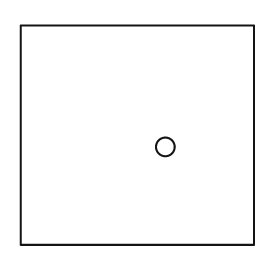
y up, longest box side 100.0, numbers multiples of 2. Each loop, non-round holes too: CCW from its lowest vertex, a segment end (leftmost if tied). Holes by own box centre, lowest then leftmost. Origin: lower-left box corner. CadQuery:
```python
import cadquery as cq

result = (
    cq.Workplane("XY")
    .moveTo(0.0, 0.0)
    .lineTo(100.0, 0.0)
    .lineTo(100.0, 94.0)
    .lineTo(0.0, 94.0)
    .close()
    .moveTo(62.0, 42.0)
    .circle(4.0)
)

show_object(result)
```